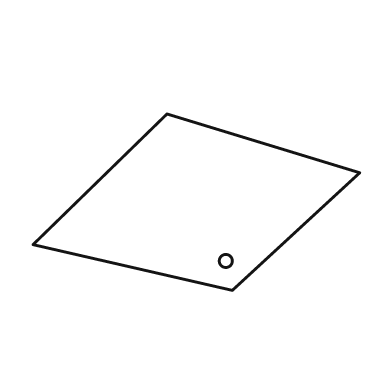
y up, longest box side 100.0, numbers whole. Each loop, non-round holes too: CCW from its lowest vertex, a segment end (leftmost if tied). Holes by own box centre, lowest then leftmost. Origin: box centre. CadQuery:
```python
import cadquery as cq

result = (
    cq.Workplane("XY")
    .moveTo(11.0, -27.0)
    .lineTo(50.0, 9.0)
    .lineTo(-9.0, 27.0)
    .lineTo(-50.0, -13.0)
    .close()
    .moveTo(9.0, -18.0)
    .circle(2.0)
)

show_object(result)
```